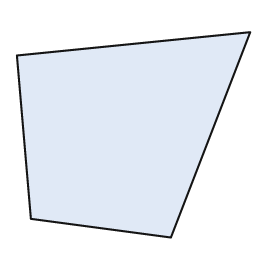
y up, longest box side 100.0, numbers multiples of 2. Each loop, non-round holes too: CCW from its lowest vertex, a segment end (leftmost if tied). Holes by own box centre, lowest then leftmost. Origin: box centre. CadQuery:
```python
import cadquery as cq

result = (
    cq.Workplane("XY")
    .moveTo(16.0, -44.0)
    .lineTo(50.0, 44.0)
    .lineTo(-50.0, 34.0)
    .lineTo(-44.0, -36.0)
    .close()
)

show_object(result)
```